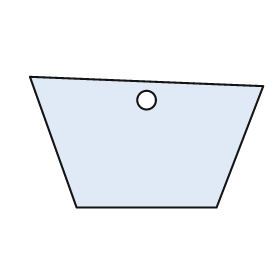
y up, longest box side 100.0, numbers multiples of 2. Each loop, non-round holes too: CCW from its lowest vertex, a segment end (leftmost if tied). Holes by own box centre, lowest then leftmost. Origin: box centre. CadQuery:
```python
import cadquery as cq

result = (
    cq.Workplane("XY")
    .moveTo(-30.0, -28.0)
    .lineTo(30.0, -28.0)
    .lineTo(50.0, 24.0)
    .lineTo(-50.0, 28.0)
    .close()
    .moveTo(0.0, 18.0)
    .circle(4.0)
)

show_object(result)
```